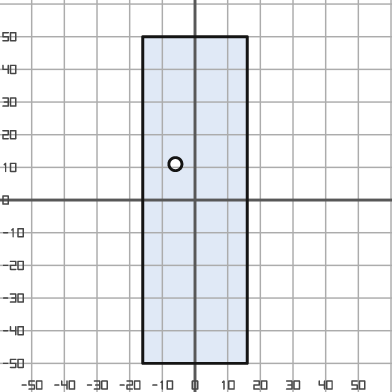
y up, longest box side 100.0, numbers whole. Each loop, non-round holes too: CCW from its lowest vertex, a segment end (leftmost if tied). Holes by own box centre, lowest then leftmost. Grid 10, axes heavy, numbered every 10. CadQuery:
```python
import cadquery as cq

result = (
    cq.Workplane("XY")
    .moveTo(-16.0, -50.0)
    .lineTo(16.0, -50.0)
    .lineTo(16.0, 50.0)
    .lineTo(-16.0, 50.0)
    .close()
    .moveTo(-6.0, 11.0)
    .circle(2.0)
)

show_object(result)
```